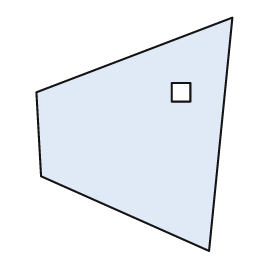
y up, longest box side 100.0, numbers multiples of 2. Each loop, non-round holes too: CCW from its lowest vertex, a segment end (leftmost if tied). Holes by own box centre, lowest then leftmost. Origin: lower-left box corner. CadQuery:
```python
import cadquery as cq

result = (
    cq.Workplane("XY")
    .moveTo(74.0, 0.0)
    .lineTo(84.0, 100.0)
    .lineTo(0.0, 68.0)
    .lineTo(2.0, 32.0)
    .close()
    .moveTo(58.0, 64.0)
    .lineTo(66.0, 64.0)
    .lineTo(66.0, 72.0)
    .lineTo(58.0, 72.0)
    .close()
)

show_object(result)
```